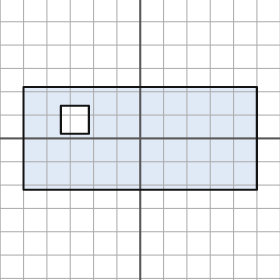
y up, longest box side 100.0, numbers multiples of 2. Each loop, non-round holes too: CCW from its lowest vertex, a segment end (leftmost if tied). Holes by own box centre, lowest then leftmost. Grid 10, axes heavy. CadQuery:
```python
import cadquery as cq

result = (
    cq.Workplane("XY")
    .moveTo(-50.0, -22.0)
    .lineTo(50.0, -22.0)
    .lineTo(50.0, 22.0)
    .lineTo(-50.0, 22.0)
    .close()
    .moveTo(-34.0, 2.0)
    .lineTo(-22.0, 2.0)
    .lineTo(-22.0, 14.0)
    .lineTo(-34.0, 14.0)
    .close()
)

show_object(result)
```